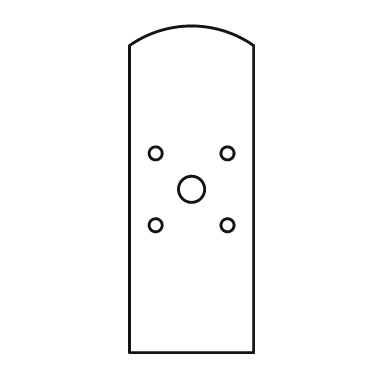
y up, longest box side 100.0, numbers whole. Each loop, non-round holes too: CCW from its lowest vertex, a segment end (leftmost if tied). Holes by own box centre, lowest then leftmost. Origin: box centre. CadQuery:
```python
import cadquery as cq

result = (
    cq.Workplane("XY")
    .moveTo(-19.0, -50.0)
    .lineTo(19.0, -50.0)
    .lineTo(19.0, 44.0)
    .threePointArc((0.0, 50.0), (-19.0, 44.0))
    .close()
    .moveTo(-11.0, -11.0)
    .circle(2.0)
    .moveTo(11.0, -11.0)
    .circle(2.0)
    .moveTo(0.0, 0.0)
    .circle(4.0)
    .moveTo(-11.0, 11.0)
    .circle(2.0)
    .moveTo(11.0, 11.0)
    .circle(2.0)
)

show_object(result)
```